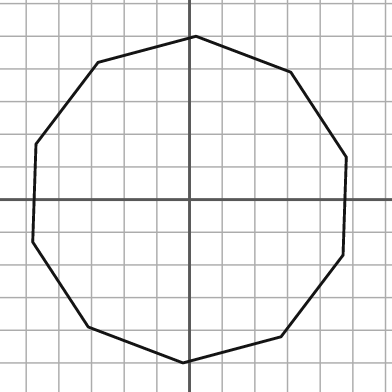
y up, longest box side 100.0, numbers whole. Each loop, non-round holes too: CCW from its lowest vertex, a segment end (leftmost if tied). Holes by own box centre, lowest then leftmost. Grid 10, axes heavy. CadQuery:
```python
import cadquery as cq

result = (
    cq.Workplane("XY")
    .moveTo(-2.0, -50.0)
    .lineTo(28.0, -42.0)
    .lineTo(47.0, -17.0)
    .lineTo(48.0, 13.0)
    .lineTo(31.0, 39.0)
    .lineTo(2.0, 50.0)
    .lineTo(-28.0, 42.0)
    .lineTo(-47.0, 17.0)
    .lineTo(-48.0, -13.0)
    .lineTo(-31.0, -39.0)
    .close()
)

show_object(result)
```